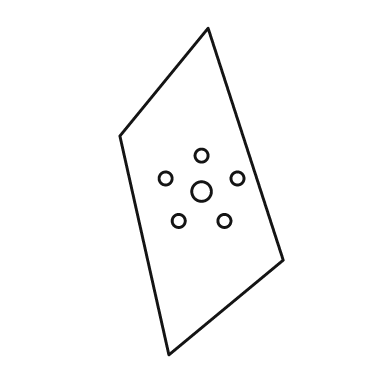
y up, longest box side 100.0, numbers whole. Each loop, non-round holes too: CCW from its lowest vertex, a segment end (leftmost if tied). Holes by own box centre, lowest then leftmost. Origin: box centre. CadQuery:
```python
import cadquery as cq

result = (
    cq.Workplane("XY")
    .moveTo(-10.0, -50.0)
    .lineTo(25.0, -21.0)
    .lineTo(2.0, 50.0)
    .lineTo(-25.0, 17.0)
    .close()
    .moveTo(-7.0, -9.0)
    .circle(2.0)
    .moveTo(7.0, -9.0)
    .circle(2.0)
    .moveTo(0.0, 0.0)
    .circle(3.0)
    .moveTo(-11.0, 4.0)
    .circle(2.0)
    .moveTo(11.0, 4.0)
    .circle(2.0)
    .moveTo(0.0, 11.0)
    .circle(2.0)
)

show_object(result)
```